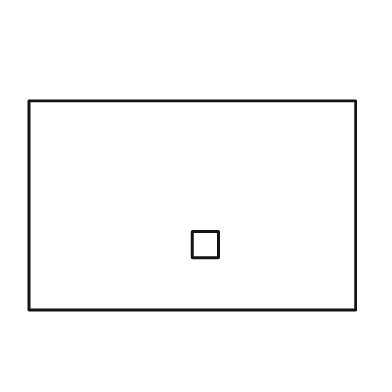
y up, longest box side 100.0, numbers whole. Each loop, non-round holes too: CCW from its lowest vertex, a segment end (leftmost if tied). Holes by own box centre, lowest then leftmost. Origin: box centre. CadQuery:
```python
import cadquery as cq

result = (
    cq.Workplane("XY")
    .moveTo(-50.0, -32.0)
    .lineTo(50.0, -32.0)
    .lineTo(50.0, 32.0)
    .lineTo(-50.0, 32.0)
    .close()
    .moveTo(0.0, -16.0)
    .lineTo(8.0, -16.0)
    .lineTo(8.0, -8.0)
    .lineTo(0.0, -8.0)
    .close()
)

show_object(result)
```